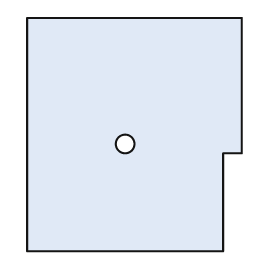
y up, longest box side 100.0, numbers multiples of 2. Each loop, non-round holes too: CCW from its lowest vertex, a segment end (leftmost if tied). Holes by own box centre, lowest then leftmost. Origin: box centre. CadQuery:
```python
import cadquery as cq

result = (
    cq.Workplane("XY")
    .moveTo(-46.0, -50.0)
    .lineTo(38.0, -50.0)
    .lineTo(38.0, -8.0)
    .lineTo(46.0, -8.0)
    .lineTo(46.0, 50.0)
    .lineTo(-46.0, 50.0)
    .close()
    .moveTo(-4.0, -4.0)
    .circle(4.0)
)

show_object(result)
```